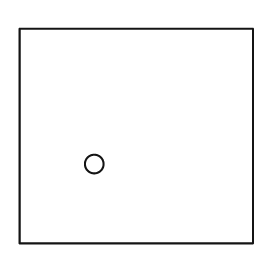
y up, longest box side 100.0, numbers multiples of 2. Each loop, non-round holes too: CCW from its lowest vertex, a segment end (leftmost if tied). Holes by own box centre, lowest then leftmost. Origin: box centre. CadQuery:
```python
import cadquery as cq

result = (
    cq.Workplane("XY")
    .moveTo(-50.0, -46.0)
    .lineTo(50.0, -46.0)
    .lineTo(50.0, 46.0)
    .lineTo(-50.0, 46.0)
    .close()
    .moveTo(-18.0, -12.0)
    .circle(4.0)
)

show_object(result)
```